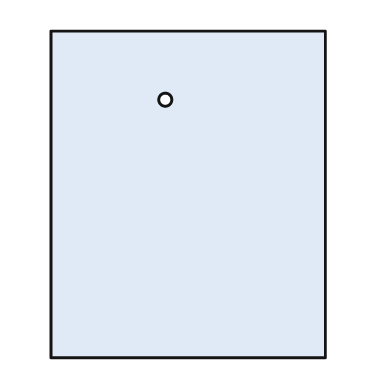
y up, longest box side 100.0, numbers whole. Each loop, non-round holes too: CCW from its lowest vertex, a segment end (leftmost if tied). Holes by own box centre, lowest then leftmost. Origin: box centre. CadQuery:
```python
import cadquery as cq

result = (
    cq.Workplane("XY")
    .moveTo(-42.0, -50.0)
    .lineTo(42.0, -50.0)
    .lineTo(42.0, 50.0)
    .lineTo(-42.0, 50.0)
    .close()
    .moveTo(-7.0, 29.0)
    .circle(2.0)
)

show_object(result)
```